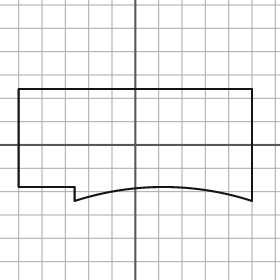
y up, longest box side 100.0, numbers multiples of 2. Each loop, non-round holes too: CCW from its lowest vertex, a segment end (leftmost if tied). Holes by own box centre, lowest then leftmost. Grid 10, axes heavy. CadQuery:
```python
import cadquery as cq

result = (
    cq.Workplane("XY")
    .moveTo(-26.0, -24.0)
    .threePointArc((12.0, -18.0), (50.0, -24.0))
    .lineTo(50.0, 24.0)
    .lineTo(-50.0, 24.0)
    .lineTo(-50.0, -18.0)
    .lineTo(-26.0, -18.0)
    .close()
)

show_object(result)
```